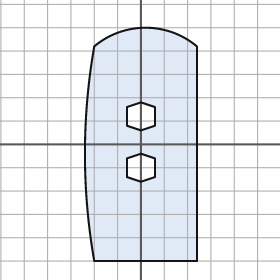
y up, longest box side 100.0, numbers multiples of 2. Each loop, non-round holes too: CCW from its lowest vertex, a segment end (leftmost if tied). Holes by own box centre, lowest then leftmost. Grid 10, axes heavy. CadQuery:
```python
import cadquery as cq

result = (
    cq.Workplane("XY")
    .moveTo(-20.0, -50.0)
    .lineTo(24.0, -50.0)
    .lineTo(24.0, 42.0)
    .threePointArc((2.0, 50.0), (-20.0, 42.0))
    .threePointArc((-24.0, -4.0), (-20.0, -50.0))
    .close()
    .moveTo(0.0, -16.0)
    .lineTo(6.0, -14.0)
    .lineTo(6.0, -6.0)
    .lineTo(0.0, -4.0)
    .lineTo(-6.0, -6.0)
    .lineTo(-6.0, -14.0)
    .close()
    .moveTo(0.0, 6.0)
    .lineTo(6.0, 8.0)
    .lineTo(6.0, 16.0)
    .lineTo(0.0, 18.0)
    .lineTo(-6.0, 16.0)
    .lineTo(-6.0, 8.0)
    .close()
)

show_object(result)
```